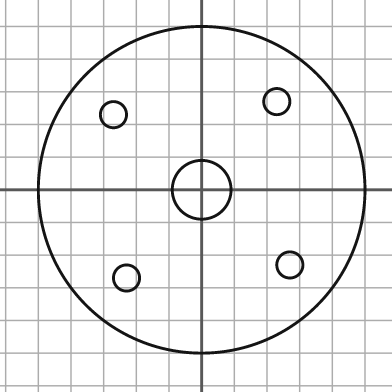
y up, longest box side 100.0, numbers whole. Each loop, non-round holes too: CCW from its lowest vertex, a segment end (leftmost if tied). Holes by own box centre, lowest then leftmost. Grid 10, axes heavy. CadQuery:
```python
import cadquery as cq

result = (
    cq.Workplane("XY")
    .moveTo(0.0, 0.0)
    .circle(50.0)
    .moveTo(-23.0, -27.0)
    .circle(4.0)
    .moveTo(27.0, -23.0)
    .circle(4.0)
    .moveTo(0.0, 0.0)
    .circle(9.0)
    .moveTo(-27.0, 23.0)
    .circle(4.0)
    .moveTo(23.0, 27.0)
    .circle(4.0)
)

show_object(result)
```